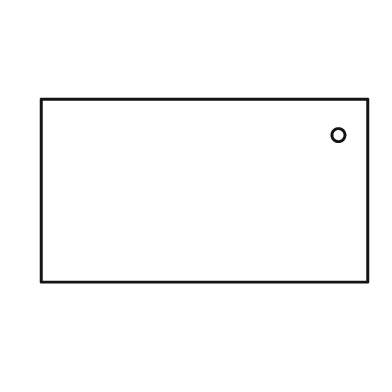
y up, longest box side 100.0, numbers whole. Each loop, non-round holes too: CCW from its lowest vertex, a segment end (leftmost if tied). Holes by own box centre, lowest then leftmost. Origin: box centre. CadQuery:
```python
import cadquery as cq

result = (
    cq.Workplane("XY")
    .moveTo(-50.0, -28.0)
    .lineTo(50.0, -28.0)
    .lineTo(50.0, 28.0)
    .lineTo(-50.0, 28.0)
    .close()
    .moveTo(41.0, 17.0)
    .circle(2.0)
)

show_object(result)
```